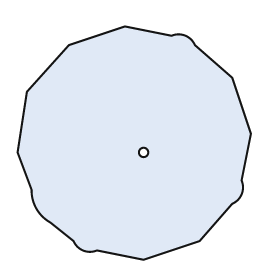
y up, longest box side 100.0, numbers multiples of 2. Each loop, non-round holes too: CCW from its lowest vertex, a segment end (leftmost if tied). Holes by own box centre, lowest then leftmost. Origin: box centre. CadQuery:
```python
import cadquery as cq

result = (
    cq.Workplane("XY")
    .moveTo(4.0, -50.0)
    .lineTo(28.0, -42.0)
    .lineTo(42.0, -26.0)
    .threePointArc((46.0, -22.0), (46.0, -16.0))
    .lineTo(50.0, 4.0)
    .lineTo(42.0, 28.0)
    .lineTo(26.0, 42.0)
    .threePointArc((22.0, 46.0), (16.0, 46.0))
    .lineTo(-4.0, 50.0)
    .lineTo(-28.0, 42.0)
    .lineTo(-46.0, 22.0)
    .lineTo(-50.0, -4.0)
    .lineTo(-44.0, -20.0)
    .threePointArc((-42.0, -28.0), (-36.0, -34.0))
    .lineTo(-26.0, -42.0)
    .threePointArc((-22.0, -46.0), (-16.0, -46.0))
    .close()
    .moveTo(4.0, -4.0)
    .circle(2.0)
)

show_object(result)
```